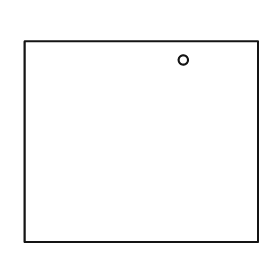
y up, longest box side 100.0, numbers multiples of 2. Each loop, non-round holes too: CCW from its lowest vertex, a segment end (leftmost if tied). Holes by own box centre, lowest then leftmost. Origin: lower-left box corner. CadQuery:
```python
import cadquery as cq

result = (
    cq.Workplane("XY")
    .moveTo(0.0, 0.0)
    .lineTo(100.0, 0.0)
    .lineTo(100.0, 86.0)
    .lineTo(0.0, 86.0)
    .close()
    .moveTo(68.0, 78.0)
    .circle(2.0)
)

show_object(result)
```